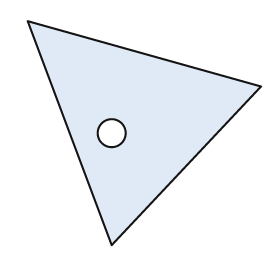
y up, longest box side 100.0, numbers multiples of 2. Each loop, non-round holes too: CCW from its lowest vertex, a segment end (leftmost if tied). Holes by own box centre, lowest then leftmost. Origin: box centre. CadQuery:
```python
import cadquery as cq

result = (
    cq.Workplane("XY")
    .moveTo(-14.0, -48.0)
    .lineTo(50.0, 20.0)
    .lineTo(-50.0, 48.0)
    .close()
    .moveTo(-14.0, 0.0)
    .circle(6.0)
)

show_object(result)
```